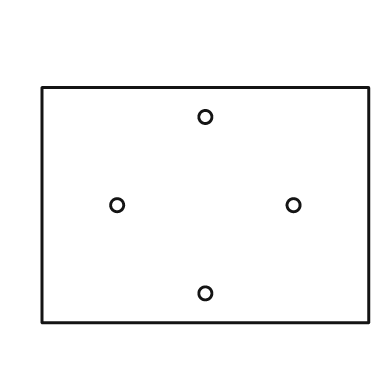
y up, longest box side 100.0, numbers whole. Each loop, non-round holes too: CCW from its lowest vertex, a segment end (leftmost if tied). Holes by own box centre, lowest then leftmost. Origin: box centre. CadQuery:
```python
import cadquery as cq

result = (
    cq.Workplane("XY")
    .moveTo(-50.0, -36.0)
    .lineTo(50.0, -36.0)
    .lineTo(50.0, 36.0)
    .lineTo(-50.0, 36.0)
    .close()
    .moveTo(0.0, -27.0)
    .circle(2.0)
    .moveTo(-27.0, 0.0)
    .circle(2.0)
    .moveTo(27.0, 0.0)
    .circle(2.0)
    .moveTo(0.0, 27.0)
    .circle(2.0)
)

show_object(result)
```